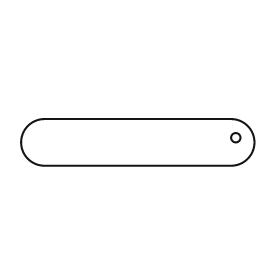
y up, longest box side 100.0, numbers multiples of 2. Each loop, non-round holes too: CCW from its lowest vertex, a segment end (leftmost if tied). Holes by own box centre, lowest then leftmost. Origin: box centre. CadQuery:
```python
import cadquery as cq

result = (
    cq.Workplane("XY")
    .moveTo(-40.0, -10.0)
    .lineTo(40.0, -10.0)
    .threePointArc((50.0, 0.0), (40.0, 10.0))
    .lineTo(-40.0, 10.0)
    .threePointArc((-50.0, 0.0), (-40.0, -10.0))
    .close()
    .moveTo(42.0, 2.0)
    .circle(2.0)
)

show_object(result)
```